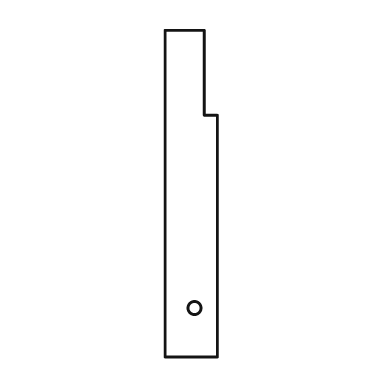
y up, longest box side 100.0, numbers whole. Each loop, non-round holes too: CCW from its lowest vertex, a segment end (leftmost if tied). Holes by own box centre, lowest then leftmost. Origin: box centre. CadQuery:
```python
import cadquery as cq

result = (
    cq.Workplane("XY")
    .moveTo(-8.0, -50.0)
    .lineTo(8.0, -50.0)
    .lineTo(8.0, 24.0)
    .lineTo(4.0, 24.0)
    .lineTo(4.0, 50.0)
    .lineTo(-8.0, 50.0)
    .close()
    .moveTo(1.0, -35.0)
    .circle(2.0)
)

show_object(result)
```